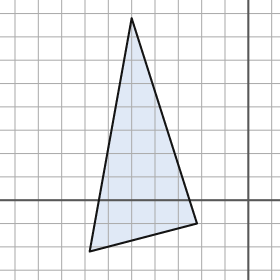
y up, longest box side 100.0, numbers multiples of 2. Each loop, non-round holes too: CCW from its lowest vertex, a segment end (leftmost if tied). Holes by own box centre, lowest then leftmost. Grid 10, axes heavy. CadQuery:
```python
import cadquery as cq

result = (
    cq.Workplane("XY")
    .moveTo(-68.0, -22.0)
    .lineTo(-22.0, -10.0)
    .lineTo(-50.0, 78.0)
    .close()
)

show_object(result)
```